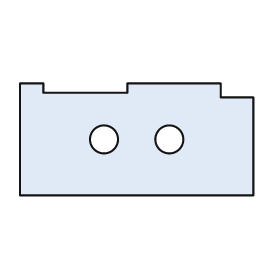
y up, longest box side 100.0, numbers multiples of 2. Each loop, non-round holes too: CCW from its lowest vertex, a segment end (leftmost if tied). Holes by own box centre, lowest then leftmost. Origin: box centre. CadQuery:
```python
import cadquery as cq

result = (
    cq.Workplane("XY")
    .moveTo(-50.0, -24.0)
    .lineTo(50.0, -24.0)
    .lineTo(50.0, 18.0)
    .lineTo(36.0, 18.0)
    .lineTo(36.0, 24.0)
    .lineTo(-4.0, 24.0)
    .lineTo(-4.0, 20.0)
    .lineTo(-40.0, 20.0)
    .lineTo(-40.0, 24.0)
    .lineTo(-50.0, 24.0)
    .close()
    .moveTo(-14.0, 0.0)
    .circle(6.0)
    .moveTo(14.0, 0.0)
    .circle(6.0)
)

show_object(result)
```